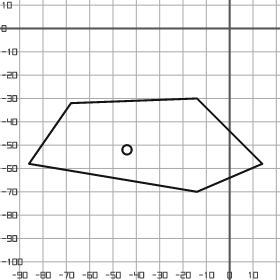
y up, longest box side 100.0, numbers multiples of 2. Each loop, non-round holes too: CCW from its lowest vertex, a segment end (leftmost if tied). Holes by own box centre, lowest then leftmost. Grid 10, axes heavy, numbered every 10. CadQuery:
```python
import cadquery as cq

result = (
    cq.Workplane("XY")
    .moveTo(-14.0, -70.0)
    .lineTo(14.0, -58.0)
    .lineTo(-14.0, -30.0)
    .lineTo(-68.0, -32.0)
    .lineTo(-86.0, -58.0)
    .close()
    .moveTo(-44.0, -52.0)
    .circle(2.0)
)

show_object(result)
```